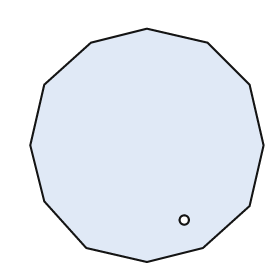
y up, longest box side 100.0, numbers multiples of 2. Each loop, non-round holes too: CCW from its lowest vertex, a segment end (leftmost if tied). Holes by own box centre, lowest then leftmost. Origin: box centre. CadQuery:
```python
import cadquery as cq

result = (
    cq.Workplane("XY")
    .moveTo(0.0, -50.0)
    .lineTo(24.0, -44.0)
    .lineTo(44.0, -26.0)
    .lineTo(50.0, 0.0)
    .lineTo(44.0, 26.0)
    .lineTo(26.0, 44.0)
    .lineTo(0.0, 50.0)
    .lineTo(-24.0, 44.0)
    .lineTo(-44.0, 26.0)
    .lineTo(-50.0, 0.0)
    .lineTo(-44.0, -24.0)
    .lineTo(-26.0, -44.0)
    .close()
    .moveTo(16.0, -32.0)
    .circle(2.0)
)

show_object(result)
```